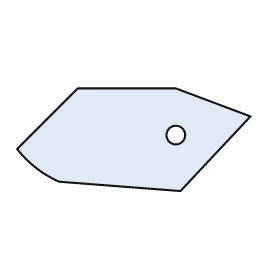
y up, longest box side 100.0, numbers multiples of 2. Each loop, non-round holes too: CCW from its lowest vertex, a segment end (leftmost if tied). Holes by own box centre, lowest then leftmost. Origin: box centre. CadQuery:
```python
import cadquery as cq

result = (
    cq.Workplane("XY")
    .moveTo(20.0, -22.0)
    .lineTo(50.0, 10.0)
    .lineTo(18.0, 22.0)
    .lineTo(-24.0, 22.0)
    .lineTo(-50.0, -4.0)
    .threePointArc((-42.0, -12.0), (-32.0, -18.0))
    .close()
    .moveTo(18.0, 2.0)
    .circle(4.0)
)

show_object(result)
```